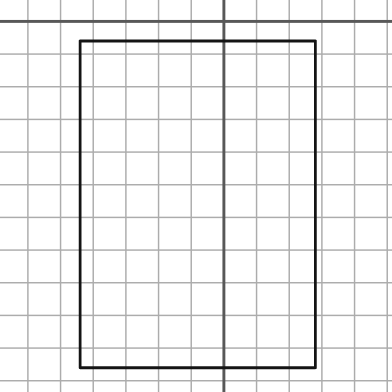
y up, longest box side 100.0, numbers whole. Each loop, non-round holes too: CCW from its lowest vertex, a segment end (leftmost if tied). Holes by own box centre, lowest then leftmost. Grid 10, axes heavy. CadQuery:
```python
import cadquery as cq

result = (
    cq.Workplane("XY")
    .moveTo(-44.0, -106.0)
    .lineTo(28.0, -106.0)
    .lineTo(28.0, -6.0)
    .lineTo(-44.0, -6.0)
    .close()
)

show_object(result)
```